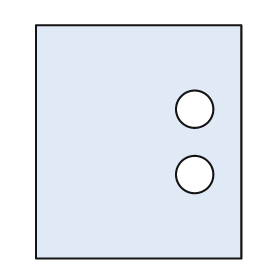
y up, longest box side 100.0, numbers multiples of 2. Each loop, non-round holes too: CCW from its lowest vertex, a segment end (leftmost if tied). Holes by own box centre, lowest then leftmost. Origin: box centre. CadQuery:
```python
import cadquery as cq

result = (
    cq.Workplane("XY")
    .moveTo(-44.0, -50.0)
    .lineTo(44.0, -50.0)
    .lineTo(44.0, 50.0)
    .lineTo(-44.0, 50.0)
    .close()
    .moveTo(24.0, -14.0)
    .circle(8.0)
    .moveTo(24.0, 14.0)
    .circle(8.0)
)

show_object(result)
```